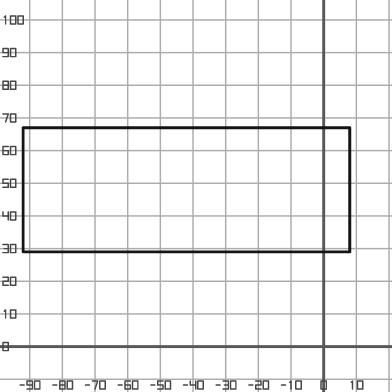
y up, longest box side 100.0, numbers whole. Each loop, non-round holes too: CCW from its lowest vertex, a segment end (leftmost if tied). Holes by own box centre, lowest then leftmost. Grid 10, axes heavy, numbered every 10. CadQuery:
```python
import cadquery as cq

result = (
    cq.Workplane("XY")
    .moveTo(-92.0, 29.0)
    .lineTo(8.0, 29.0)
    .lineTo(8.0, 67.0)
    .lineTo(-92.0, 67.0)
    .close()
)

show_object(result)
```